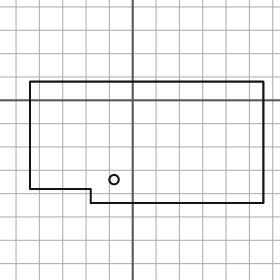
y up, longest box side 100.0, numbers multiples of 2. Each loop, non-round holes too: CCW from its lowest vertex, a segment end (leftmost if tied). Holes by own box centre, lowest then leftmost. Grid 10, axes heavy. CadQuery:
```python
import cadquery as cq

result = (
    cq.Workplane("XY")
    .moveTo(-18.0, -44.0)
    .lineTo(56.0, -44.0)
    .lineTo(56.0, 8.0)
    .lineTo(-44.0, 8.0)
    .lineTo(-44.0, -38.0)
    .lineTo(-18.0, -38.0)
    .close()
    .moveTo(-8.0, -34.0)
    .circle(2.0)
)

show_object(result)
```